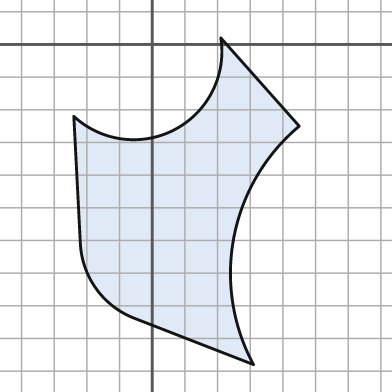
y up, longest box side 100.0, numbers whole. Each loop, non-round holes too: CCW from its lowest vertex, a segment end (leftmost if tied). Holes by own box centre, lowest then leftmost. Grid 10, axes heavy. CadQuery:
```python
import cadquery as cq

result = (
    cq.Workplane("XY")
    .moveTo(31.0, -98.0)
    .threePointArc((25.0, -59.0), (45.0, -25.0))
    .lineTo(21.0, 2.0)
    .threePointArc((7.0, -26.0), (-24.0, -22.0))
    .lineTo(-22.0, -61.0)
    .threePointArc((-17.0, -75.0), (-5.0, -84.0))
    .close()
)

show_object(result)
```